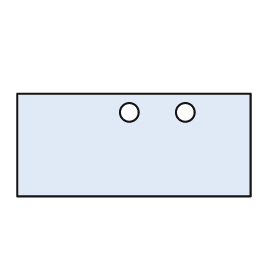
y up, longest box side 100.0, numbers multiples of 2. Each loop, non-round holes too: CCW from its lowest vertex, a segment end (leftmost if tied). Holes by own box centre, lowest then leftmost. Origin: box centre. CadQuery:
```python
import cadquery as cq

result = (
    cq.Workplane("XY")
    .moveTo(-50.0, -22.0)
    .lineTo(50.0, -22.0)
    .lineTo(50.0, 22.0)
    .lineTo(-50.0, 22.0)
    .close()
    .moveTo(-2.0, 14.0)
    .circle(4.0)
    .moveTo(22.0, 14.0)
    .circle(4.0)
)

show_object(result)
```